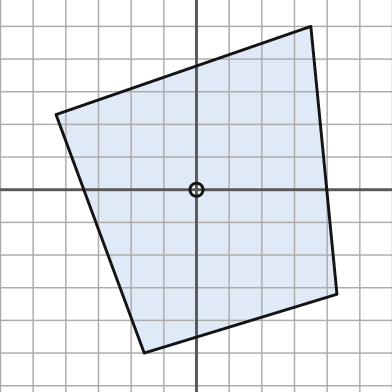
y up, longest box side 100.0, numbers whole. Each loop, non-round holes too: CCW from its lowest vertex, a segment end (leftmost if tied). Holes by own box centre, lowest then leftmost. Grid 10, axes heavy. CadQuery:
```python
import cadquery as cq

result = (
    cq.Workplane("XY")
    .moveTo(-16.0, -50.0)
    .lineTo(43.0, -32.0)
    .lineTo(35.0, 50.0)
    .lineTo(-43.0, 23.0)
    .close()
    .moveTo(0.0, 0.0)
    .circle(2.0)
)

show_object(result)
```